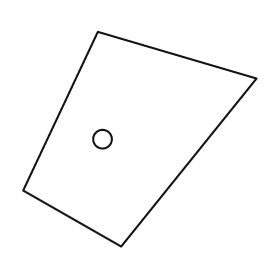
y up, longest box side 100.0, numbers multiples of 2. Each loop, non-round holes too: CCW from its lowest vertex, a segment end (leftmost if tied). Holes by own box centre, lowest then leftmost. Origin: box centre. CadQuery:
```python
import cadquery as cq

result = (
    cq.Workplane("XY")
    .moveTo(-8.0, -46.0)
    .lineTo(50.0, 26.0)
    .lineTo(-18.0, 46.0)
    .lineTo(-50.0, -22.0)
    .close()
    .moveTo(-16.0, 0.0)
    .circle(4.0)
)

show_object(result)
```